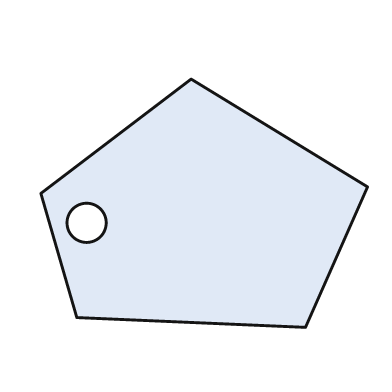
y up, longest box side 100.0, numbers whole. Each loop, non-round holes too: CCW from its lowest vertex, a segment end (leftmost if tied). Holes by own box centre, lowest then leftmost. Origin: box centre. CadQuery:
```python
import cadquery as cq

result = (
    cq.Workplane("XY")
    .moveTo(31.0, -38.0)
    .lineTo(50.0, 5.0)
    .lineTo(-4.0, 38.0)
    .lineTo(-50.0, 3.0)
    .lineTo(-39.0, -35.0)
    .close()
    .moveTo(-36.0, -6.0)
    .circle(6.0)
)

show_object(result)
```